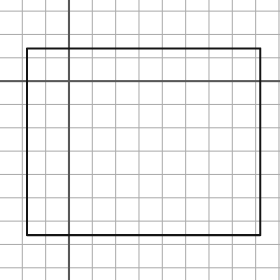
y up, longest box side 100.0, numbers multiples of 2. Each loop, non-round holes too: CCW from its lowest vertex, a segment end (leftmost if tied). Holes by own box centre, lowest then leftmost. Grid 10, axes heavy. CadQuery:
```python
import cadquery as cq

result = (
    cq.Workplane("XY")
    .moveTo(-18.0, -66.0)
    .lineTo(82.0, -66.0)
    .lineTo(82.0, 14.0)
    .lineTo(-18.0, 14.0)
    .close()
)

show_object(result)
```